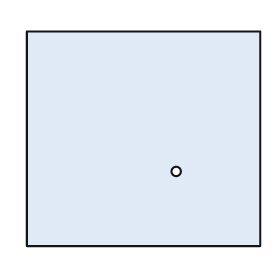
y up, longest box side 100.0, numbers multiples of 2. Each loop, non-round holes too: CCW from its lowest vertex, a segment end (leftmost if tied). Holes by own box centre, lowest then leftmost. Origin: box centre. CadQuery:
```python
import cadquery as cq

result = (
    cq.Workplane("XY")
    .moveTo(-50.0, -46.0)
    .lineTo(50.0, -46.0)
    .lineTo(50.0, 46.0)
    .lineTo(-50.0, 46.0)
    .close()
    .moveTo(14.0, -14.0)
    .circle(2.0)
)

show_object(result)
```